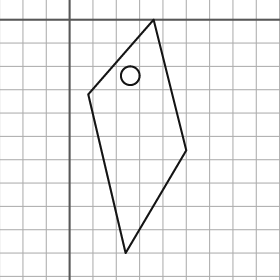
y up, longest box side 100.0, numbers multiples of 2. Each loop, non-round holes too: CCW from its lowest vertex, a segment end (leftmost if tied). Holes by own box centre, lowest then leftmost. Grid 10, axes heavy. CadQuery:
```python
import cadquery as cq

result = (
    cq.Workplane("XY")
    .moveTo(24.0, -100.0)
    .lineTo(50.0, -56.0)
    .lineTo(36.0, 0.0)
    .lineTo(8.0, -32.0)
    .close()
    .moveTo(26.0, -24.0)
    .circle(4.0)
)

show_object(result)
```